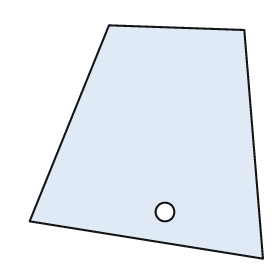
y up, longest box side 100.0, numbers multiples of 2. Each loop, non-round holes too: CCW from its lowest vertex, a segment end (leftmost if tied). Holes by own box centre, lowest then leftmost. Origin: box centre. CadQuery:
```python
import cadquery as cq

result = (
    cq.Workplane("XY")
    .moveTo(50.0, -50.0)
    .lineTo(42.0, 48.0)
    .lineTo(-16.0, 50.0)
    .lineTo(-50.0, -34.0)
    .close()
    .moveTo(8.0, -30.0)
    .circle(4.0)
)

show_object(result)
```